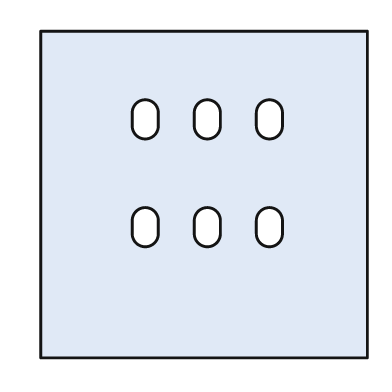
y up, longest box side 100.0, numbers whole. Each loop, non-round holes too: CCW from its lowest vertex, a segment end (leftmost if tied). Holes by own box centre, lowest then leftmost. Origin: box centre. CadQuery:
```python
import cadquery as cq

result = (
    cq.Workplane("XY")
    .moveTo(-50.0, -50.0)
    .lineTo(50.0, -50.0)
    .lineTo(50.0, 50.0)
    .lineTo(-50.0, 50.0)
    .close()
    .moveTo(-22.0, -12.0)
    .threePointArc((-18.0, -16.0), (-14.0, -12.0))
    .lineTo(-14.0, -8.0)
    .threePointArc((-18.0, -4.0), (-22.0, -8.0))
    .close()
    .moveTo(-3.0, -12.0)
    .threePointArc((1.0, -16.0), (5.0, -12.0))
    .lineTo(5.0, -8.0)
    .threePointArc((1.0, -4.0), (-3.0, -8.0))
    .close()
    .moveTo(16.0, -12.0)
    .threePointArc((20.0, -16.0), (24.0, -12.0))
    .lineTo(24.0, -8.0)
    .threePointArc((20.0, -4.0), (16.0, -8.0))
    .close()
    .moveTo(-22.0, 21.0)
    .threePointArc((-18.0, 17.0), (-14.0, 21.0))
    .lineTo(-14.0, 25.0)
    .threePointArc((-18.0, 29.0), (-22.0, 25.0))
    .close()
    .moveTo(-3.0, 21.0)
    .threePointArc((1.0, 17.0), (5.0, 21.0))
    .lineTo(5.0, 25.0)
    .threePointArc((1.0, 29.0), (-3.0, 25.0))
    .close()
    .moveTo(16.0, 21.0)
    .threePointArc((20.0, 17.0), (24.0, 21.0))
    .lineTo(24.0, 25.0)
    .threePointArc((20.0, 29.0), (16.0, 25.0))
    .close()
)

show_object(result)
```